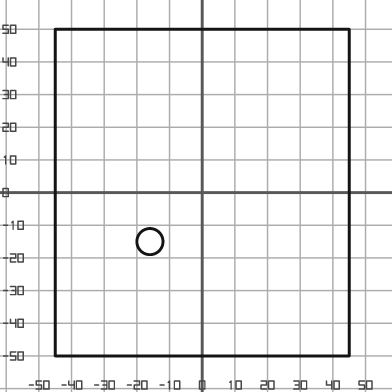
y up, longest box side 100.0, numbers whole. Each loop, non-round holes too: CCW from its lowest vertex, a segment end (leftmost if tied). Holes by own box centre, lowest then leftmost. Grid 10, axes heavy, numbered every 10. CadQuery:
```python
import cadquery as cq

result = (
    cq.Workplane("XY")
    .moveTo(-45.0, -50.0)
    .lineTo(45.0, -50.0)
    .lineTo(45.0, 50.0)
    .lineTo(-45.0, 50.0)
    .close()
    .moveTo(-16.0, -15.0)
    .circle(4.0)
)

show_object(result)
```